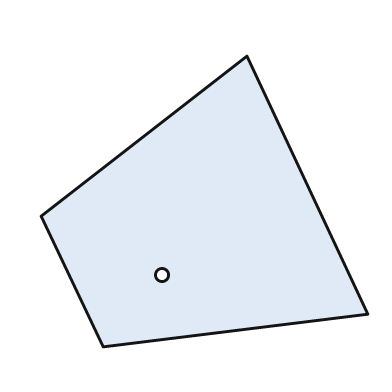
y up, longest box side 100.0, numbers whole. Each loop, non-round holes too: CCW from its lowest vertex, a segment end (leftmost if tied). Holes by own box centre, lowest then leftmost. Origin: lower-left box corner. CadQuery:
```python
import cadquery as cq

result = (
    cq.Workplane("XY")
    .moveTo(19.0, 0.0)
    .lineTo(100.0, 10.0)
    .lineTo(63.0, 89.0)
    .lineTo(0.0, 40.0)
    .close()
    .moveTo(37.0, 22.0)
    .circle(2.0)
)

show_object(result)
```